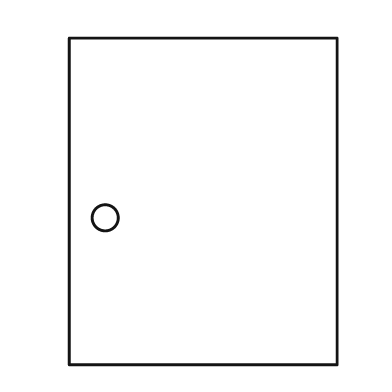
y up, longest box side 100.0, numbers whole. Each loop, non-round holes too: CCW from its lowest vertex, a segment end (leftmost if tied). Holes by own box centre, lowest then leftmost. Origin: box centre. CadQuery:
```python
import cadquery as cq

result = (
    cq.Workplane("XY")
    .moveTo(-41.0, -50.0)
    .lineTo(41.0, -50.0)
    .lineTo(41.0, 50.0)
    .lineTo(-41.0, 50.0)
    .close()
    .moveTo(-30.0, -5.0)
    .circle(4.0)
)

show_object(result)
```